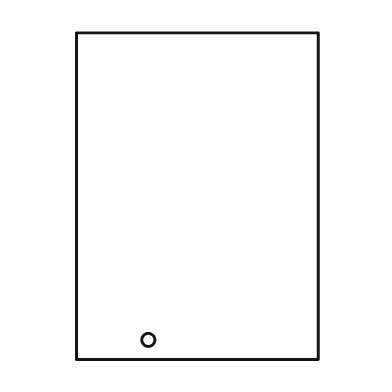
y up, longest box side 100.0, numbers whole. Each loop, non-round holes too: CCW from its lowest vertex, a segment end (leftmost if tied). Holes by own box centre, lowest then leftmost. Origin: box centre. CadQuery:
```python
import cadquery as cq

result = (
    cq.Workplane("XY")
    .moveTo(-37.0, -50.0)
    .lineTo(37.0, -50.0)
    .lineTo(37.0, 50.0)
    .lineTo(-37.0, 50.0)
    .close()
    .moveTo(-15.0, -44.0)
    .circle(2.0)
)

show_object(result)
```